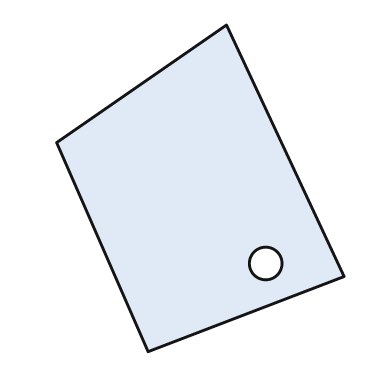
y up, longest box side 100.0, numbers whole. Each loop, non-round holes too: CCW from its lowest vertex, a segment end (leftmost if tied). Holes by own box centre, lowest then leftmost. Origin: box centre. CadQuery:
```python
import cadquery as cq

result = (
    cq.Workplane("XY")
    .moveTo(-16.0, -50.0)
    .lineTo(44.0, -27.0)
    .lineTo(8.0, 50.0)
    .lineTo(-44.0, 14.0)
    .close()
    .moveTo(20.0, -23.0)
    .circle(5.0)
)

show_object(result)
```